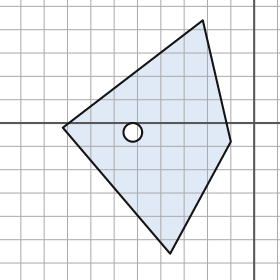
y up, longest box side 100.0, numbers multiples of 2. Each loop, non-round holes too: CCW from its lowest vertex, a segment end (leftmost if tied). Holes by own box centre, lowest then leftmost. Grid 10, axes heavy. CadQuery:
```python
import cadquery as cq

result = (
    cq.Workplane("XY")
    .moveTo(-36.0, -56.0)
    .lineTo(-10.0, -8.0)
    .lineTo(-22.0, 44.0)
    .lineTo(-82.0, -2.0)
    .close()
    .moveTo(-52.0, -4.0)
    .circle(4.0)
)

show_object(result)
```